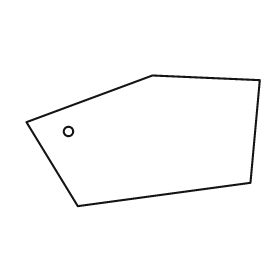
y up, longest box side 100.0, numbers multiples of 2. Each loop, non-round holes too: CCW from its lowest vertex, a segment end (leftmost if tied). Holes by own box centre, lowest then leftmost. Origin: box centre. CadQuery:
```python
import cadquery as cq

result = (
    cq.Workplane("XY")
    .moveTo(-28.0, -28.0)
    .lineTo(46.0, -18.0)
    .lineTo(50.0, 26.0)
    .lineTo(4.0, 28.0)
    .lineTo(-50.0, 8.0)
    .close()
    .moveTo(-32.0, 4.0)
    .circle(2.0)
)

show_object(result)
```